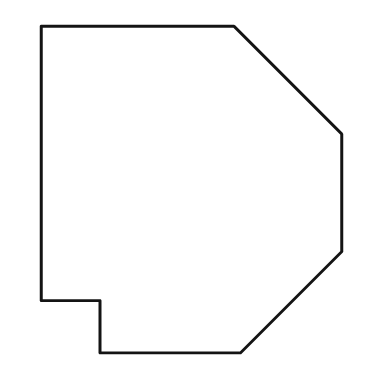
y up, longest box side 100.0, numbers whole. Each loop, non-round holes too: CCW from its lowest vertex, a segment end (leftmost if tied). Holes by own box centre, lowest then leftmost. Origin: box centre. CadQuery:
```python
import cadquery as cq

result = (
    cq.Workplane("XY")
    .moveTo(-28.0, -50.0)
    .lineTo(15.0, -50.0)
    .lineTo(46.0, -19.0)
    .lineTo(46.0, 17.0)
    .lineTo(13.0, 50.0)
    .lineTo(-46.0, 50.0)
    .lineTo(-46.0, -34.0)
    .lineTo(-28.0, -34.0)
    .close()
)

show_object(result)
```